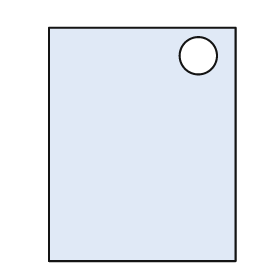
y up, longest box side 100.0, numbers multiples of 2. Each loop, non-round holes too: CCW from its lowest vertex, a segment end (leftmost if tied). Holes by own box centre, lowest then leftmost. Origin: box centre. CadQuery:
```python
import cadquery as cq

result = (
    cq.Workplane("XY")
    .moveTo(-40.0, -50.0)
    .lineTo(40.0, -50.0)
    .lineTo(40.0, 50.0)
    .lineTo(-40.0, 50.0)
    .close()
    .moveTo(24.0, 38.0)
    .circle(8.0)
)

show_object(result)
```